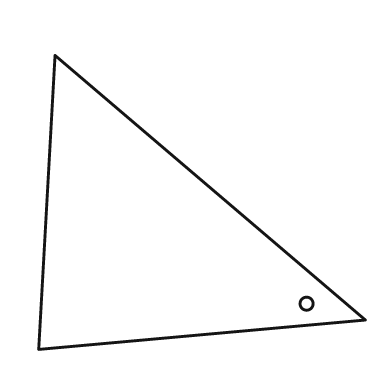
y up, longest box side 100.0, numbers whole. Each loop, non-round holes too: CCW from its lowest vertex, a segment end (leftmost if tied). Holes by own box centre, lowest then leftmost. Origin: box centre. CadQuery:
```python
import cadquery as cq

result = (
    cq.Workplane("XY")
    .moveTo(-50.0, -45.0)
    .lineTo(50.0, -36.0)
    .lineTo(-45.0, 45.0)
    .close()
    .moveTo(32.0, -31.0)
    .circle(2.0)
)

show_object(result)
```